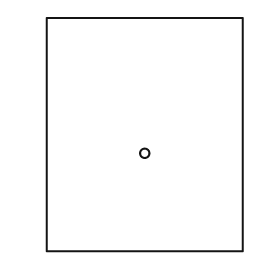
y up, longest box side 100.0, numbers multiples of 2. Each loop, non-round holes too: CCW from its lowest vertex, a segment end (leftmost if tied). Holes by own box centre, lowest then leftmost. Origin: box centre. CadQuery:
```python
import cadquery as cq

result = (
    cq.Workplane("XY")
    .moveTo(-42.0, -50.0)
    .lineTo(42.0, -50.0)
    .lineTo(42.0, 50.0)
    .lineTo(-42.0, 50.0)
    .close()
    .moveTo(0.0, -8.0)
    .circle(2.0)
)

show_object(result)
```